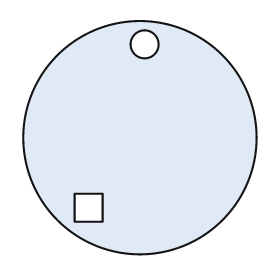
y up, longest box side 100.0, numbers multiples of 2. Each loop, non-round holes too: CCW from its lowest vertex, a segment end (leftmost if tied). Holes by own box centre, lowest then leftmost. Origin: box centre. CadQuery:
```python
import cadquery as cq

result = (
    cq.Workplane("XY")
    .moveTo(0.0, 0.0)
    .circle(50.0)
    .moveTo(-28.0, -36.0)
    .lineTo(-16.0, -36.0)
    .lineTo(-16.0, -24.0)
    .lineTo(-28.0, -24.0)
    .close()
    .moveTo(2.0, 40.0)
    .circle(6.0)
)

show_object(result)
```